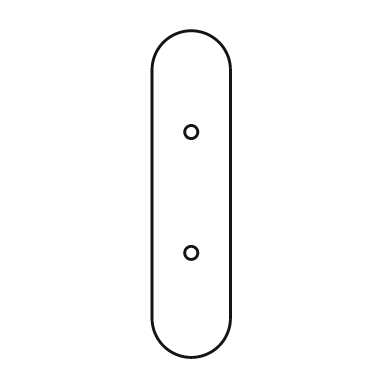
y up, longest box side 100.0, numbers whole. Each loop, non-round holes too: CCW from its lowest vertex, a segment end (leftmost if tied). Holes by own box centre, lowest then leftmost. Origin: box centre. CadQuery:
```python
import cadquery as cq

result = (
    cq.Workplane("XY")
    .moveTo(-12.0, -38.0)
    .threePointArc((0.0, -50.0), (12.0, -38.0))
    .lineTo(12.0, 38.0)
    .threePointArc((0.0, 50.0), (-12.0, 38.0))
    .close()
    .moveTo(0.0, -18.0)
    .circle(2.0)
    .moveTo(0.0, 19.0)
    .circle(2.0)
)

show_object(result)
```